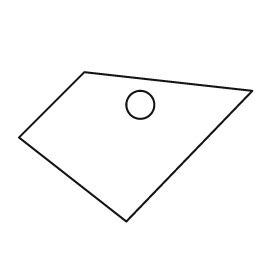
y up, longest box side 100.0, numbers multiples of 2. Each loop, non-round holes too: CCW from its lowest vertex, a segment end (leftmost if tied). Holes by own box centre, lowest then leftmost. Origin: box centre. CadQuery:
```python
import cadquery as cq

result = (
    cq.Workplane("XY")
    .moveTo(-4.0, -32.0)
    .lineTo(50.0, 24.0)
    .lineTo(-22.0, 32.0)
    .lineTo(-50.0, 4.0)
    .close()
    .moveTo(2.0, 18.0)
    .circle(6.0)
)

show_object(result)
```